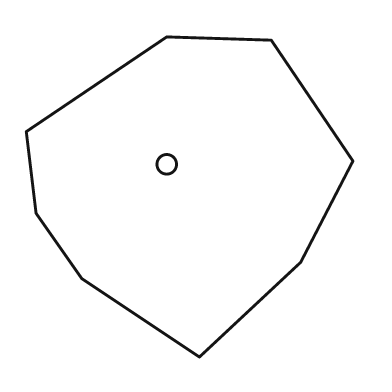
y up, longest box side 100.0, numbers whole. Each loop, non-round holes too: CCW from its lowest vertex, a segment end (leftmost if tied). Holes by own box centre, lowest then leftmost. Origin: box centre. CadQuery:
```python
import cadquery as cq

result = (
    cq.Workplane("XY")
    .moveTo(3.0, -49.0)
    .lineTo(34.0, -20.0)
    .lineTo(50.0, 11.0)
    .lineTo(25.0, 48.0)
    .lineTo(-7.0, 49.0)
    .lineTo(-50.0, 20.0)
    .lineTo(-47.0, -5.0)
    .lineTo(-33.0, -25.0)
    .close()
    .moveTo(-7.0, 10.0)
    .circle(3.0)
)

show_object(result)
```